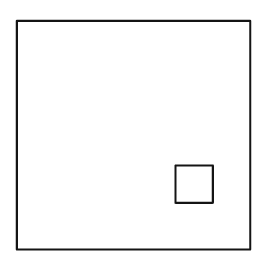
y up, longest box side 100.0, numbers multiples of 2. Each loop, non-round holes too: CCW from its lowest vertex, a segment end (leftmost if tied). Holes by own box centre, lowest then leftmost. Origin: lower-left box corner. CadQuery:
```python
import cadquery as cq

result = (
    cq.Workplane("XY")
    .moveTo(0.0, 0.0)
    .lineTo(100.0, 0.0)
    .lineTo(100.0, 98.0)
    .lineTo(0.0, 98.0)
    .close()
    .moveTo(68.0, 20.0)
    .lineTo(84.0, 20.0)
    .lineTo(84.0, 36.0)
    .lineTo(68.0, 36.0)
    .close()
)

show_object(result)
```